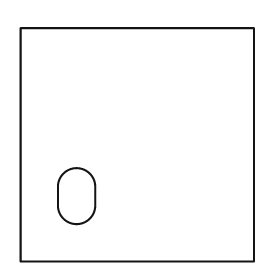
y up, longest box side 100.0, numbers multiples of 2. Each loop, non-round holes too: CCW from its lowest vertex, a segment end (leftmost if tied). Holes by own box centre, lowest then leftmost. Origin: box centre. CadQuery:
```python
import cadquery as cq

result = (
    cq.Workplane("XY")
    .moveTo(-50.0, -50.0)
    .lineTo(50.0, -50.0)
    .lineTo(50.0, 50.0)
    .lineTo(-50.0, 50.0)
    .close()
    .moveTo(-34.0, -26.0)
    .threePointArc((-26.0, -34.0), (-18.0, -26.0))
    .lineTo(-18.0, -18.0)
    .threePointArc((-26.0, -10.0), (-34.0, -18.0))
    .close()
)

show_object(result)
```